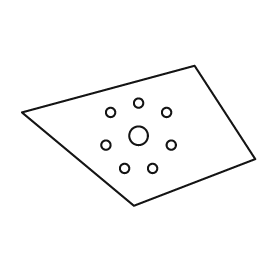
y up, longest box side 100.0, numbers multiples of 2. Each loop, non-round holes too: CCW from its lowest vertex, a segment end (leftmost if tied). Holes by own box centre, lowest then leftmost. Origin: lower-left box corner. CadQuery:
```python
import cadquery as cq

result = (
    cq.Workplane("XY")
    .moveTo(48.0, 0.0)
    .lineTo(100.0, 20.0)
    .lineTo(74.0, 60.0)
    .lineTo(0.0, 40.0)
    .close()
    .moveTo(44.0, 16.0)
    .circle(2.0)
    .moveTo(56.0, 16.0)
    .circle(2.0)
    .moveTo(36.0, 26.0)
    .circle(2.0)
    .moveTo(64.0, 26.0)
    .circle(2.0)
    .moveTo(50.0, 30.0)
    .circle(4.0)
    .moveTo(38.0, 40.0)
    .circle(2.0)
    .moveTo(62.0, 40.0)
    .circle(2.0)
    .moveTo(50.0, 44.0)
    .circle(2.0)
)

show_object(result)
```